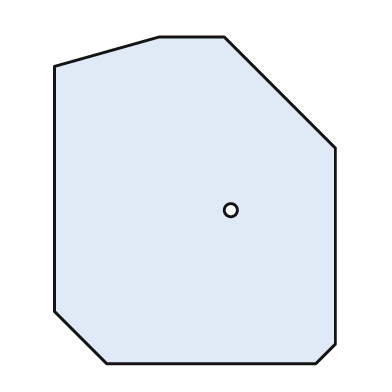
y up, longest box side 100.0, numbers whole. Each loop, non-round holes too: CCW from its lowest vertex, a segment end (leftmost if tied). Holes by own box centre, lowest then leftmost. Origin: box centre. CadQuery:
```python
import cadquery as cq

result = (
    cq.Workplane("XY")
    .moveTo(-27.0, -50.0)
    .lineTo(37.0, -50.0)
    .lineTo(43.0, -44.0)
    .lineTo(43.0, 16.0)
    .lineTo(9.0, 50.0)
    .lineTo(-11.0, 50.0)
    .lineTo(-43.0, 41.0)
    .lineTo(-43.0, -34.0)
    .close()
    .moveTo(11.0, -3.0)
    .circle(2.0)
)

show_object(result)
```